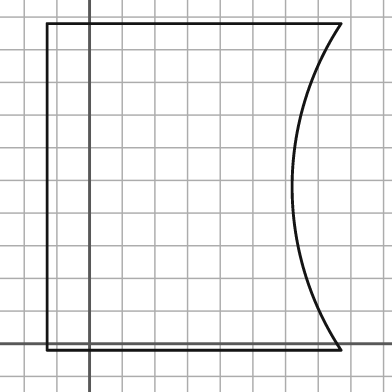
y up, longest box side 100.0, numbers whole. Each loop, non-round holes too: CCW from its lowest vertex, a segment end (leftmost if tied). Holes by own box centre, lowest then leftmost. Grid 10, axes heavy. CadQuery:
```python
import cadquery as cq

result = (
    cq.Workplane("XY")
    .moveTo(-13.0, -2.0)
    .lineTo(77.0, -2.0)
    .threePointArc((62.0, 48.0), (77.0, 98.0))
    .lineTo(-13.0, 98.0)
    .close()
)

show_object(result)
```